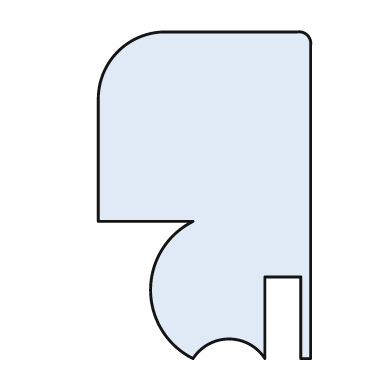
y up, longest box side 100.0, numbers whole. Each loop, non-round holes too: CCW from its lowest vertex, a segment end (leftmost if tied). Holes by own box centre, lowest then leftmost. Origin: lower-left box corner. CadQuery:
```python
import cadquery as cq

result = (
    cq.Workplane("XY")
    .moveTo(29.0, 0.0)
    .threePointArc((40.0, 6.0), (51.0, 0.0))
    .lineTo(51.0, 25.0)
    .lineTo(62.0, 25.0)
    .lineTo(62.0, 0.0)
    .lineTo(65.0, 0.0)
    .lineTo(65.0, 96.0)
    .threePointArc((64.0, 99.0), (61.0, 100.0))
    .lineTo(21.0, 100.0)
    .threePointArc((6.0, 94.0), (0.0, 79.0))
    .lineTo(0.0, 42.0)
    .lineTo(29.0, 42.0)
    .threePointArc((16.0, 21.0), (29.0, 0.0))
    .close()
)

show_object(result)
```